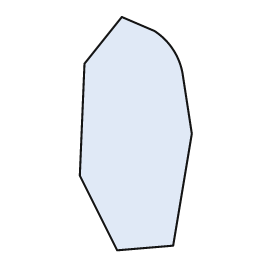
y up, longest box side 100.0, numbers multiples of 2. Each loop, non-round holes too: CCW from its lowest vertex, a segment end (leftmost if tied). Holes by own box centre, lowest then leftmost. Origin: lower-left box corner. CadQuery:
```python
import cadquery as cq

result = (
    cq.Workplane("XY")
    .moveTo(16.0, 0.0)
    .lineTo(40.0, 2.0)
    .lineTo(48.0, 50.0)
    .lineTo(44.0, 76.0)
    .threePointArc((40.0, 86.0), (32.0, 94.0))
    .lineTo(18.0, 100.0)
    .lineTo(2.0, 80.0)
    .lineTo(0.0, 32.0)
    .close()
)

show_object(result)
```